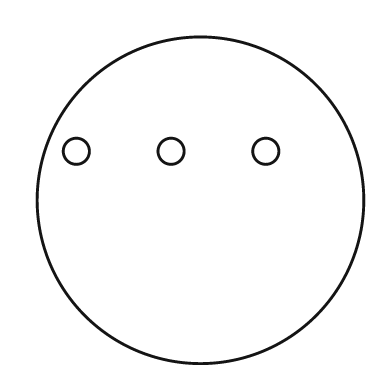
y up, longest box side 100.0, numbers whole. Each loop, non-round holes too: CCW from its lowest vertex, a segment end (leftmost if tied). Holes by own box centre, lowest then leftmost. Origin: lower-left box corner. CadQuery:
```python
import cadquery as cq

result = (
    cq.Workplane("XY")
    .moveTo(50.0, 50.0)
    .circle(50.0)
    .moveTo(12.0, 65.0)
    .circle(4.0)
    .moveTo(41.0, 65.0)
    .circle(4.0)
    .moveTo(70.0, 65.0)
    .circle(4.0)
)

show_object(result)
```